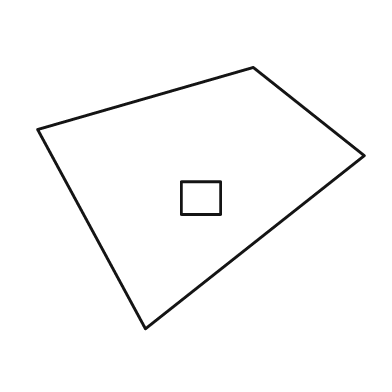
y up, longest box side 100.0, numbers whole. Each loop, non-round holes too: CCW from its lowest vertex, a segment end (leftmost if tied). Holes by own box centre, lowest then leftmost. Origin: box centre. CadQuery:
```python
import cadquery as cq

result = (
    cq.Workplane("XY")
    .moveTo(-17.0, -40.0)
    .lineTo(50.0, 13.0)
    .lineTo(16.0, 40.0)
    .lineTo(-50.0, 21.0)
    .close()
    .moveTo(-6.0, -5.0)
    .lineTo(6.0, -5.0)
    .lineTo(6.0, 5.0)
    .lineTo(-6.0, 5.0)
    .close()
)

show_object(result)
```